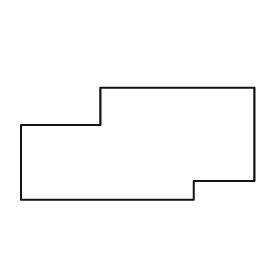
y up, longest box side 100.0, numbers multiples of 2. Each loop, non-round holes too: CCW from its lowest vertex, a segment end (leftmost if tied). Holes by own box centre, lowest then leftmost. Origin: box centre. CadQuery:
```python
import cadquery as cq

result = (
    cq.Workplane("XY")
    .moveTo(-50.0, -24.0)
    .lineTo(24.0, -24.0)
    .lineTo(24.0, -16.0)
    .lineTo(50.0, -16.0)
    .lineTo(50.0, 24.0)
    .lineTo(-16.0, 24.0)
    .lineTo(-16.0, 8.0)
    .lineTo(-50.0, 8.0)
    .close()
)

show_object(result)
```